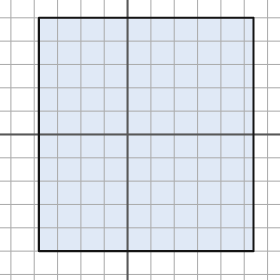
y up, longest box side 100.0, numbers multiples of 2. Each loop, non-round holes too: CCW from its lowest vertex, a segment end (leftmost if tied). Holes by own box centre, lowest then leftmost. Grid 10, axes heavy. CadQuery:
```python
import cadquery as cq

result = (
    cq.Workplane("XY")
    .moveTo(-38.0, -50.0)
    .lineTo(54.0, -50.0)
    .lineTo(54.0, 50.0)
    .lineTo(-38.0, 50.0)
    .close()
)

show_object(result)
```